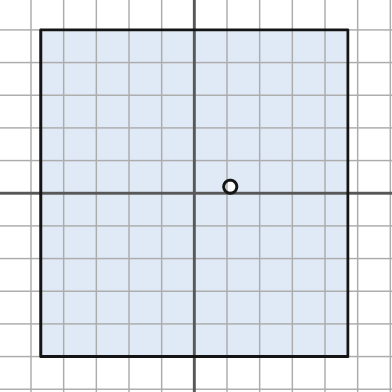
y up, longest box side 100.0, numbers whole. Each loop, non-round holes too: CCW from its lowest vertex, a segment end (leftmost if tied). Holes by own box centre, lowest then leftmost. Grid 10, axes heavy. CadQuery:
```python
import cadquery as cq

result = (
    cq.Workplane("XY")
    .moveTo(-47.0, -50.0)
    .lineTo(47.0, -50.0)
    .lineTo(47.0, 50.0)
    .lineTo(-47.0, 50.0)
    .close()
    .moveTo(11.0, 2.0)
    .circle(2.0)
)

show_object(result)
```